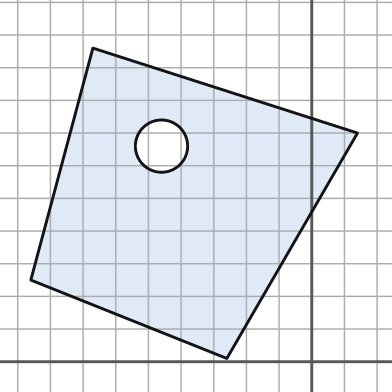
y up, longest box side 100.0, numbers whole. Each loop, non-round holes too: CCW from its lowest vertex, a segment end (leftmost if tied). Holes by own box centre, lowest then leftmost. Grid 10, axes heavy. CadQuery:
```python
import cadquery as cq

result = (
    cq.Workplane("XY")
    .moveTo(-26.0, 1.0)
    .lineTo(14.0, 70.0)
    .lineTo(-67.0, 96.0)
    .lineTo(-86.0, 25.0)
    .close()
    .moveTo(-46.0, 66.0)
    .circle(8.0)
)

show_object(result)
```